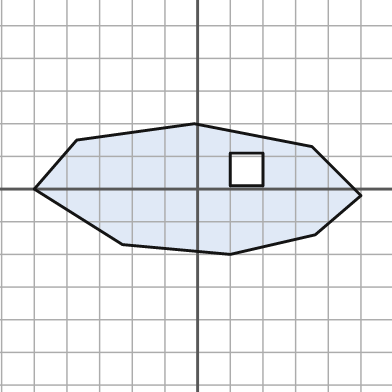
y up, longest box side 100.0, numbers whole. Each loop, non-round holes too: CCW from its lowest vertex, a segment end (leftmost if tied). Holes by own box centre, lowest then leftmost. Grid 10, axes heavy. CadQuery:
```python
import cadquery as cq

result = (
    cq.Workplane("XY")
    .moveTo(10.0, -20.0)
    .lineTo(36.0, -14.0)
    .lineTo(50.0, -2.0)
    .lineTo(35.0, 13.0)
    .lineTo(-1.0, 20.0)
    .lineTo(-37.0, 15.0)
    .lineTo(-50.0, 0.0)
    .lineTo(-23.0, -17.0)
    .close()
    .moveTo(10.0, 1.0)
    .lineTo(20.0, 1.0)
    .lineTo(20.0, 11.0)
    .lineTo(10.0, 11.0)
    .close()
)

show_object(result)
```